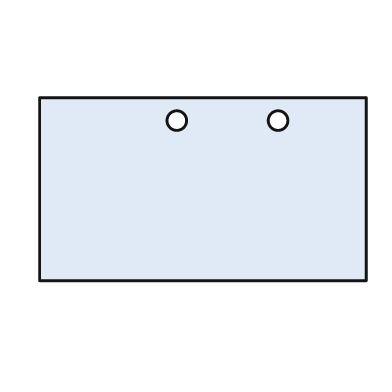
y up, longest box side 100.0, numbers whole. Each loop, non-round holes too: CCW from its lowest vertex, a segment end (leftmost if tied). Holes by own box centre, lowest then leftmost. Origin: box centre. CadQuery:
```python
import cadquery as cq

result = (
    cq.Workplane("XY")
    .moveTo(-50.0, -28.0)
    .lineTo(50.0, -28.0)
    .lineTo(50.0, 28.0)
    .lineTo(-50.0, 28.0)
    .close()
    .moveTo(-8.0, 21.0)
    .circle(3.0)
    .moveTo(23.0, 21.0)
    .circle(3.0)
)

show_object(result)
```